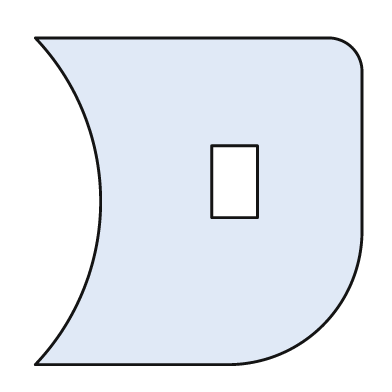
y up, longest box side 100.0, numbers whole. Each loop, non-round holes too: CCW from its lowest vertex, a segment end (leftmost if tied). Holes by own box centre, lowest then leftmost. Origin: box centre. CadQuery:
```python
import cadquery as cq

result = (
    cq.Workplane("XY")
    .moveTo(-50.0, -50.0)
    .lineTo(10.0, -50.0)
    .threePointArc((38.0, -38.0), (50.0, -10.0))
    .lineTo(50.0, 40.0)
    .threePointArc((47.0, 47.0), (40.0, 50.0))
    .lineTo(-50.0, 50.0)
    .threePointArc((-30.0, 0.0), (-50.0, -50.0))
    .close()
    .moveTo(4.0, -5.0)
    .lineTo(18.0, -5.0)
    .lineTo(18.0, 17.0)
    .lineTo(4.0, 17.0)
    .close()
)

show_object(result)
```